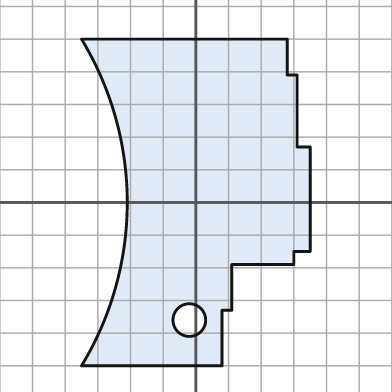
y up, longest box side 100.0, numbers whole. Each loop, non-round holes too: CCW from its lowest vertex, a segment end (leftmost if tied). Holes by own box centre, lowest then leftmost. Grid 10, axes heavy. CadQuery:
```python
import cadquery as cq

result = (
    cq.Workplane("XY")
    .moveTo(-35.0, -50.0)
    .lineTo(8.0, -50.0)
    .lineTo(8.0, -33.0)
    .lineTo(11.0, -33.0)
    .lineTo(11.0, -19.0)
    .lineTo(30.0, -19.0)
    .lineTo(30.0, -15.0)
    .lineTo(35.0, -15.0)
    .lineTo(35.0, 17.0)
    .lineTo(31.0, 17.0)
    .lineTo(31.0, 39.0)
    .lineTo(28.0, 39.0)
    .lineTo(28.0, 50.0)
    .lineTo(-35.0, 50.0)
    .threePointArc((-21.0, 0.0), (-35.0, -50.0))
    .close()
    .moveTo(-2.0, -36.0)
    .circle(5.0)
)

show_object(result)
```